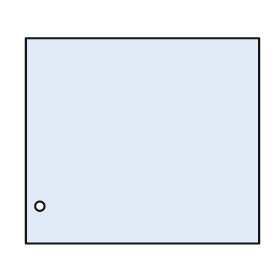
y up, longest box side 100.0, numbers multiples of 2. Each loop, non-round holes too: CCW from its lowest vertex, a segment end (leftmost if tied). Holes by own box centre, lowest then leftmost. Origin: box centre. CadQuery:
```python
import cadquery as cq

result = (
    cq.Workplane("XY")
    .moveTo(-50.0, -44.0)
    .lineTo(50.0, -44.0)
    .lineTo(50.0, 44.0)
    .lineTo(-50.0, 44.0)
    .close()
    .moveTo(-44.0, -28.0)
    .circle(2.0)
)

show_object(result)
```